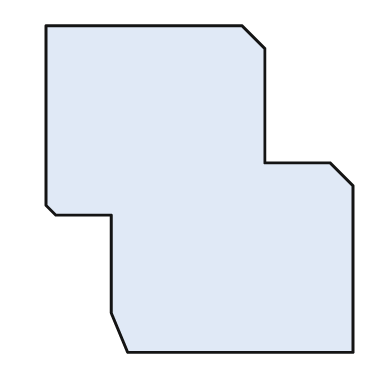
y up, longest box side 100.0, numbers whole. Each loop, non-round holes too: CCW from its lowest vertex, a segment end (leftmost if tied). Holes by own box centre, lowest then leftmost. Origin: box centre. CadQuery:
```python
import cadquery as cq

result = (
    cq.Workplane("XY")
    .moveTo(-22.0, -50.0)
    .lineTo(47.0, -50.0)
    .lineTo(47.0, 1.0)
    .lineTo(40.0, 8.0)
    .lineTo(20.0, 8.0)
    .lineTo(20.0, 43.0)
    .lineTo(13.0, 50.0)
    .lineTo(-47.0, 50.0)
    .lineTo(-47.0, -5.0)
    .lineTo(-44.0, -8.0)
    .lineTo(-27.0, -8.0)
    .lineTo(-27.0, -38.0)
    .close()
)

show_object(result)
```